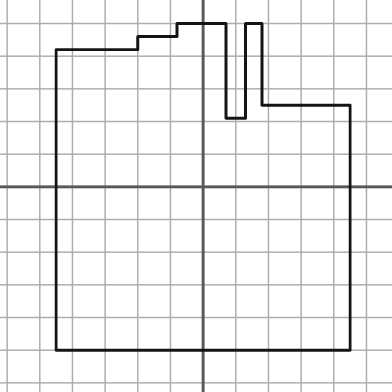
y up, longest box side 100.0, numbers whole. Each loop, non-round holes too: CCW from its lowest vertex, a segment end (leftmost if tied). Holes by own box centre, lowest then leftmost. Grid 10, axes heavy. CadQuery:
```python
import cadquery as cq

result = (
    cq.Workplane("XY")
    .moveTo(-45.0, -50.0)
    .lineTo(45.0, -50.0)
    .lineTo(45.0, 25.0)
    .lineTo(18.0, 25.0)
    .lineTo(18.0, 50.0)
    .lineTo(13.0, 50.0)
    .lineTo(13.0, 21.0)
    .lineTo(7.0, 21.0)
    .lineTo(7.0, 50.0)
    .lineTo(-8.0, 50.0)
    .lineTo(-8.0, 46.0)
    .lineTo(-20.0, 46.0)
    .lineTo(-20.0, 42.0)
    .lineTo(-45.0, 42.0)
    .close()
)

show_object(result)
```